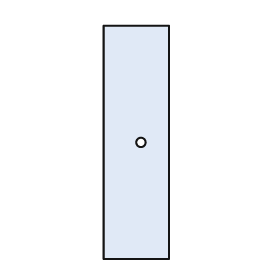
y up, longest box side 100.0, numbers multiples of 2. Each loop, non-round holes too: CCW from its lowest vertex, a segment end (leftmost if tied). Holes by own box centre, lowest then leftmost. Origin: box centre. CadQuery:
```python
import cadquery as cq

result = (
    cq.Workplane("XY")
    .moveTo(-14.0, -50.0)
    .lineTo(14.0, -50.0)
    .lineTo(14.0, 50.0)
    .lineTo(-14.0, 50.0)
    .close()
    .moveTo(2.0, 0.0)
    .circle(2.0)
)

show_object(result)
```